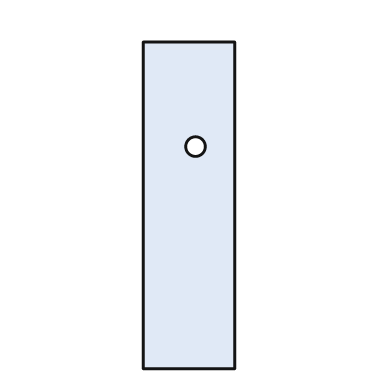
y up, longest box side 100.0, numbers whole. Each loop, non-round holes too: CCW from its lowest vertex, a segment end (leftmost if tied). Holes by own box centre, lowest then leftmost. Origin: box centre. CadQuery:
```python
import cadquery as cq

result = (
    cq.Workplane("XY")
    .moveTo(-14.0, -50.0)
    .lineTo(14.0, -50.0)
    .lineTo(14.0, 50.0)
    .lineTo(-14.0, 50.0)
    .close()
    .moveTo(2.0, 18.0)
    .circle(3.0)
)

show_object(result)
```